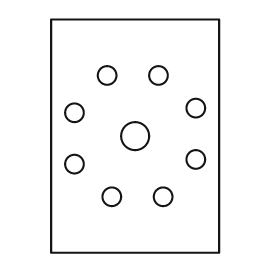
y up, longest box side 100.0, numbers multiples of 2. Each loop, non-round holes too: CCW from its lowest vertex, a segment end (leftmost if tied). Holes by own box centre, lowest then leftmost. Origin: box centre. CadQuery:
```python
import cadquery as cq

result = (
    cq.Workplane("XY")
    .moveTo(-36.0, -50.0)
    .lineTo(36.0, -50.0)
    .lineTo(36.0, 50.0)
    .lineTo(-36.0, 50.0)
    .close()
    .moveTo(-10.0, -26.0)
    .circle(4.0)
    .moveTo(12.0, -26.0)
    .circle(4.0)
    .moveTo(-26.0, -12.0)
    .circle(4.0)
    .moveTo(26.0, -10.0)
    .circle(4.0)
    .moveTo(0.0, 0.0)
    .circle(6.0)
    .moveTo(-26.0, 10.0)
    .circle(4.0)
    .moveTo(26.0, 12.0)
    .circle(4.0)
    .moveTo(-12.0, 26.0)
    .circle(4.0)
    .moveTo(10.0, 26.0)
    .circle(4.0)
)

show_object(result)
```